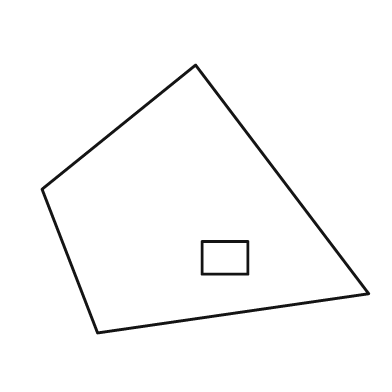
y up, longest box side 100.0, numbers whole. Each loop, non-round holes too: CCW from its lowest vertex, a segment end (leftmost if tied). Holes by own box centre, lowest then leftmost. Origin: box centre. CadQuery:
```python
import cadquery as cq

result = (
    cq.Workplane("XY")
    .moveTo(-33.0, -41.0)
    .lineTo(50.0, -29.0)
    .lineTo(-3.0, 41.0)
    .lineTo(-50.0, 3.0)
    .close()
    .moveTo(-1.0, -23.0)
    .lineTo(13.0, -23.0)
    .lineTo(13.0, -13.0)
    .lineTo(-1.0, -13.0)
    .close()
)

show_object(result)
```